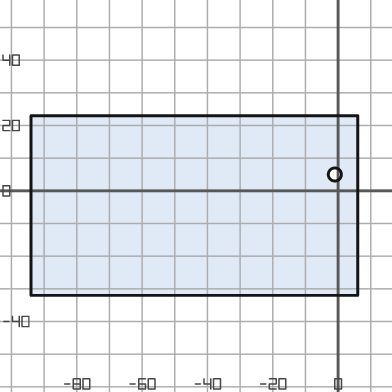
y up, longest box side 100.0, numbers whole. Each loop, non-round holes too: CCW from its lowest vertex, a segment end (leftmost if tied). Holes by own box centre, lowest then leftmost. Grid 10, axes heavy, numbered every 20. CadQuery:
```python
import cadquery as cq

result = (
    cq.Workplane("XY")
    .moveTo(-94.0, -32.0)
    .lineTo(6.0, -32.0)
    .lineTo(6.0, 23.0)
    .lineTo(-94.0, 23.0)
    .close()
    .moveTo(-1.0, 5.0)
    .circle(2.0)
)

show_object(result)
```